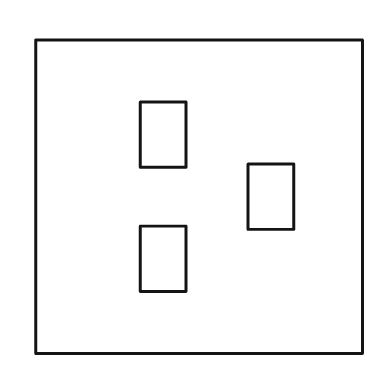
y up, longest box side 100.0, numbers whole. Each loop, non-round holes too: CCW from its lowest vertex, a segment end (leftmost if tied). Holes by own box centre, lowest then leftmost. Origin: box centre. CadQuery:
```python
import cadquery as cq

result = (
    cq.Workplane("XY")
    .moveTo(-50.0, -48.0)
    .lineTo(50.0, -48.0)
    .lineTo(50.0, 48.0)
    .lineTo(-50.0, 48.0)
    .close()
    .moveTo(-18.0, -29.0)
    .lineTo(-4.0, -29.0)
    .lineTo(-4.0, -9.0)
    .lineTo(-18.0, -9.0)
    .close()
    .moveTo(15.0, -10.0)
    .lineTo(29.0, -10.0)
    .lineTo(29.0, 10.0)
    .lineTo(15.0, 10.0)
    .close()
    .moveTo(-18.0, 9.0)
    .lineTo(-4.0, 9.0)
    .lineTo(-4.0, 29.0)
    .lineTo(-18.0, 29.0)
    .close()
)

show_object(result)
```